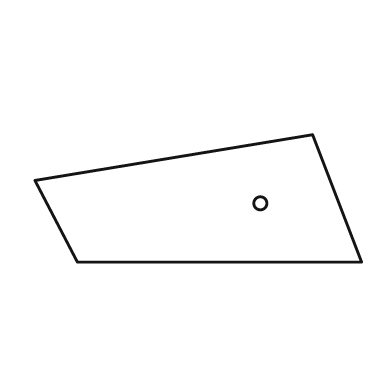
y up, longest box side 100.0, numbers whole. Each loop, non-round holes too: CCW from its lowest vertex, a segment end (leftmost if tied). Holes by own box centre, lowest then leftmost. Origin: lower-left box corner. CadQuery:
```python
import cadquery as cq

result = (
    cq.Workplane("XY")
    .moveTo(13.0, 0.0)
    .lineTo(100.0, 0.0)
    .lineTo(85.0, 39.0)
    .lineTo(0.0, 25.0)
    .close()
    .moveTo(69.0, 18.0)
    .circle(2.0)
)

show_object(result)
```